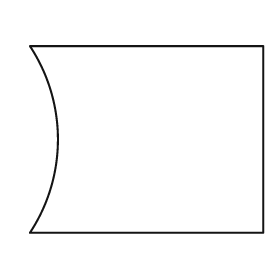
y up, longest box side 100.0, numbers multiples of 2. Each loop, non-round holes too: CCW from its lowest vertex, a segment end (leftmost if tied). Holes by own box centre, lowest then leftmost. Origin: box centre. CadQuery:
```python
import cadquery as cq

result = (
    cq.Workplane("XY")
    .moveTo(-50.0, -40.0)
    .lineTo(50.0, -40.0)
    .lineTo(50.0, 40.0)
    .lineTo(-50.0, 40.0)
    .threePointArc((-38.0, 0.0), (-50.0, -40.0))
    .close()
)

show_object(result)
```